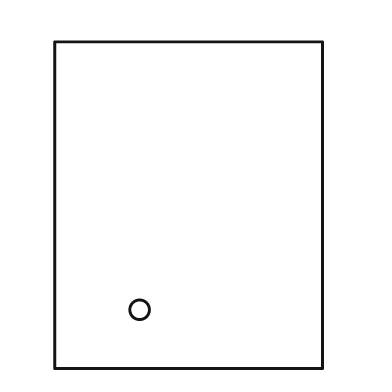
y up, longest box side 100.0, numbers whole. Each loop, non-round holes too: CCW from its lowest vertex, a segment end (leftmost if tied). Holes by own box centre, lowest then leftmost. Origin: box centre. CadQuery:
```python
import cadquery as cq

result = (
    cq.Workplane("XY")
    .moveTo(-41.0, -50.0)
    .lineTo(41.0, -50.0)
    .lineTo(41.0, 50.0)
    .lineTo(-41.0, 50.0)
    .close()
    .moveTo(-15.0, -32.0)
    .circle(3.0)
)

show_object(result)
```